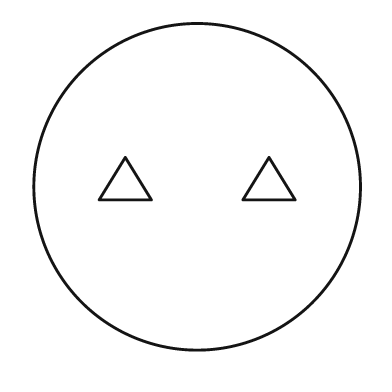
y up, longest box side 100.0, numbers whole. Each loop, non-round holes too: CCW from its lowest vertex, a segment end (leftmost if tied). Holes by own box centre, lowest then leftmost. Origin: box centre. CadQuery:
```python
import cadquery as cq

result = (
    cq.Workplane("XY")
    .moveTo(0.0, 0.0)
    .circle(50.0)
    .moveTo(-30.0, -4.0)
    .lineTo(-14.0, -4.0)
    .lineTo(-22.0, 9.0)
    .close()
    .moveTo(14.0, -4.0)
    .lineTo(30.0, -4.0)
    .lineTo(22.0, 9.0)
    .close()
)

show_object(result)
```